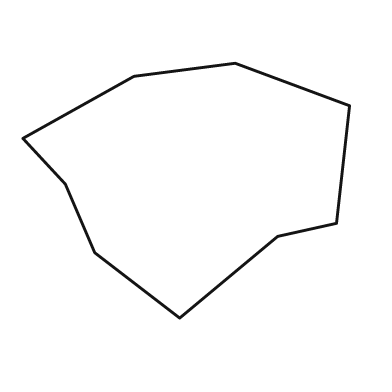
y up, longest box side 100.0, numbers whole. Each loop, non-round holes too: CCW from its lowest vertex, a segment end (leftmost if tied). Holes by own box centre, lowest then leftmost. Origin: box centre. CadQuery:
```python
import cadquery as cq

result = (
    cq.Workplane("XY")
    .moveTo(-2.0, -39.0)
    .lineTo(28.0, -14.0)
    .lineTo(46.0, -10.0)
    .lineTo(50.0, 26.0)
    .lineTo(15.0, 39.0)
    .lineTo(-16.0, 35.0)
    .lineTo(-50.0, 16.0)
    .lineTo(-37.0, 2.0)
    .lineTo(-28.0, -19.0)
    .close()
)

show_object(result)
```